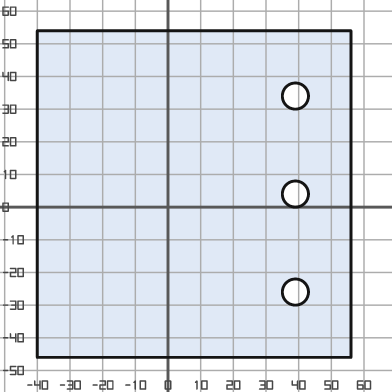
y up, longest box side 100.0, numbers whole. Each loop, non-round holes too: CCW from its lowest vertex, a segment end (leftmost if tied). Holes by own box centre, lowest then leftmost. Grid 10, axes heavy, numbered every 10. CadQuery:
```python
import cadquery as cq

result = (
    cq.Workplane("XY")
    .moveTo(-40.0, -46.0)
    .lineTo(56.0, -46.0)
    .lineTo(56.0, 54.0)
    .lineTo(-40.0, 54.0)
    .close()
    .moveTo(39.0, -26.0)
    .circle(4.0)
    .moveTo(39.0, 4.0)
    .circle(4.0)
    .moveTo(39.0, 34.0)
    .circle(4.0)
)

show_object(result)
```